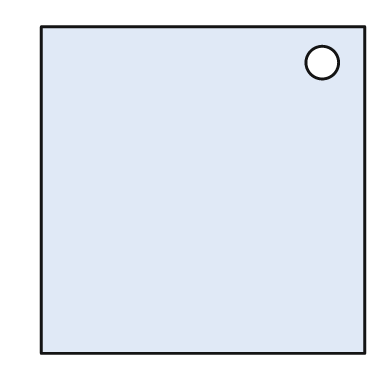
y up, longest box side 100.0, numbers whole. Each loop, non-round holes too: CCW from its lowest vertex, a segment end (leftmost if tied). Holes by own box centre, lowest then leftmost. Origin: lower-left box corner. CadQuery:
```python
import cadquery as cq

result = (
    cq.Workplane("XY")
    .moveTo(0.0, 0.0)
    .lineTo(99.0, 0.0)
    .lineTo(99.0, 100.0)
    .lineTo(0.0, 100.0)
    .close()
    .moveTo(86.0, 89.0)
    .circle(5.0)
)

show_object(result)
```